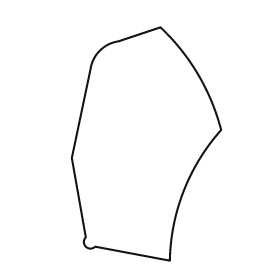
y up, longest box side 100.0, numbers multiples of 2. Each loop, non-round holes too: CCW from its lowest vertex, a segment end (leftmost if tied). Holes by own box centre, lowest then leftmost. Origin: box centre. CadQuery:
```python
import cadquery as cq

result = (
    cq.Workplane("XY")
    .moveTo(10.0, -50.0)
    .threePointArc((16.0, -20.0), (32.0, 6.0))
    .threePointArc((22.0, 30.0), (6.0, 50.0))
    .lineTo(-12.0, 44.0)
    .threePointArc((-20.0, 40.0), (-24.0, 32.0))
    .lineTo(-32.0, -6.0)
    .lineTo(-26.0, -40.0)
    .threePointArc((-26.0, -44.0), (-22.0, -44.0))
    .close()
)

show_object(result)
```